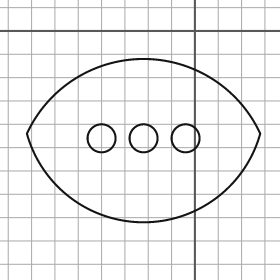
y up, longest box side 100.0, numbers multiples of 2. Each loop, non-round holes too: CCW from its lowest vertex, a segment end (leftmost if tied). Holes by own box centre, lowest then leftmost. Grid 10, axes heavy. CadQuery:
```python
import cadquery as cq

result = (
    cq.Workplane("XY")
    .moveTo(-72.0, -44.0)
    .threePointArc((-22.0, -82.0), (28.0, -44.0))
    .threePointArc((-22.0, -12.0), (-72.0, -44.0))
    .close()
    .moveTo(-40.0, -46.0)
    .circle(6.0)
    .moveTo(-22.0, -46.0)
    .circle(6.0)
    .moveTo(-4.0, -46.0)
    .circle(6.0)
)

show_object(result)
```